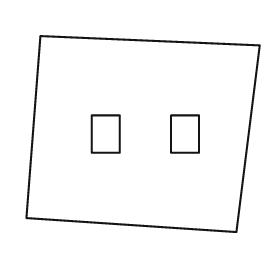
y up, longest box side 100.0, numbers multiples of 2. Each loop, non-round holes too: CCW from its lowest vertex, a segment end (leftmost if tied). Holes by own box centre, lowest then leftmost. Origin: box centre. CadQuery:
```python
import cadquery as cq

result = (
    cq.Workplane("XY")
    .moveTo(40.0, -42.0)
    .lineTo(50.0, 38.0)
    .lineTo(-44.0, 42.0)
    .lineTo(-50.0, -36.0)
    .close()
    .moveTo(-22.0, -8.0)
    .lineTo(-10.0, -8.0)
    .lineTo(-10.0, 8.0)
    .lineTo(-22.0, 8.0)
    .close()
    .moveTo(12.0, -8.0)
    .lineTo(24.0, -8.0)
    .lineTo(24.0, 8.0)
    .lineTo(12.0, 8.0)
    .close()
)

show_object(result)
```